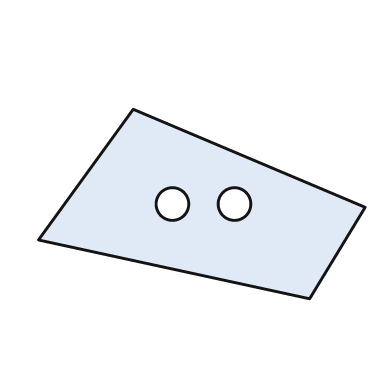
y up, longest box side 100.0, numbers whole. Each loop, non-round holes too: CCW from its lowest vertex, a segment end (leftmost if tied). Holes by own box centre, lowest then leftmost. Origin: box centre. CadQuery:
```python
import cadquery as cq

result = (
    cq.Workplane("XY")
    .moveTo(33.0, -29.0)
    .lineTo(50.0, -1.0)
    .lineTo(-21.0, 29.0)
    .lineTo(-50.0, -11.0)
    .close()
    .moveTo(-9.0, 0.0)
    .circle(5.0)
    .moveTo(10.0, 0.0)
    .circle(5.0)
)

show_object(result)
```